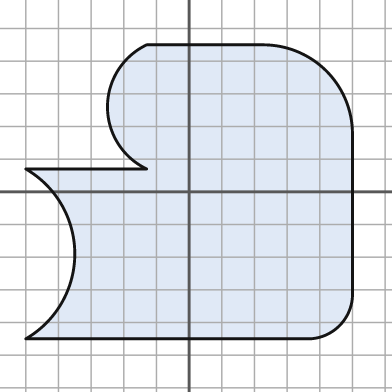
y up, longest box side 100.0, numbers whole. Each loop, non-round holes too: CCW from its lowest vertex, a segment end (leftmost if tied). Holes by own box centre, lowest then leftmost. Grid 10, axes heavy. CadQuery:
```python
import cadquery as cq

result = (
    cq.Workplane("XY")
    .moveTo(-50.0, -45.0)
    .lineTo(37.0, -45.0)
    .threePointArc((46.0, -41.0), (50.0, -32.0))
    .lineTo(50.0, 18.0)
    .threePointArc((42.0, 37.0), (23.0, 45.0))
    .lineTo(-13.0, 45.0)
    .threePointArc((-25.0, 26.0), (-13.0, 7.0))
    .lineTo(-50.0, 7.0)
    .threePointArc((-35.0, -19.0), (-50.0, -45.0))
    .close()
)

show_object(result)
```